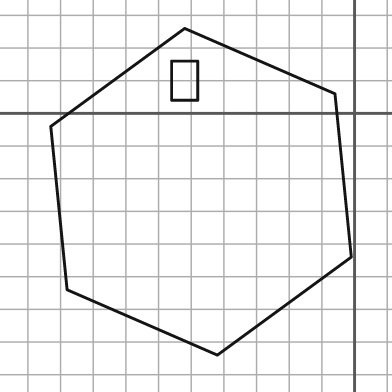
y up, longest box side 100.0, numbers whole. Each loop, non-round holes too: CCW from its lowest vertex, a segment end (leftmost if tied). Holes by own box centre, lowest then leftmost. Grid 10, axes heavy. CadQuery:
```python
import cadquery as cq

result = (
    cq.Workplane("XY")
    .moveTo(-42.0, -74.0)
    .lineTo(-1.0, -44.0)
    .lineTo(-6.0, 6.0)
    .lineTo(-52.0, 26.0)
    .lineTo(-93.0, -4.0)
    .lineTo(-88.0, -54.0)
    .close()
    .moveTo(-56.0, 4.0)
    .lineTo(-48.0, 4.0)
    .lineTo(-48.0, 16.0)
    .lineTo(-56.0, 16.0)
    .close()
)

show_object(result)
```